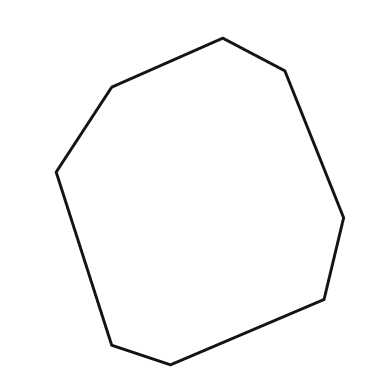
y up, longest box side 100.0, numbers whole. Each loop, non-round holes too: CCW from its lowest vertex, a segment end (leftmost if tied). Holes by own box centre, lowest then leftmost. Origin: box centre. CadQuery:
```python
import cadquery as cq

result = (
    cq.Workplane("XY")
    .moveTo(-9.0, -50.0)
    .lineTo(38.0, -30.0)
    .lineTo(44.0, -5.0)
    .lineTo(26.0, 40.0)
    .lineTo(7.0, 50.0)
    .lineTo(-27.0, 35.0)
    .lineTo(-44.0, 9.0)
    .lineTo(-27.0, -44.0)
    .close()
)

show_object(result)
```